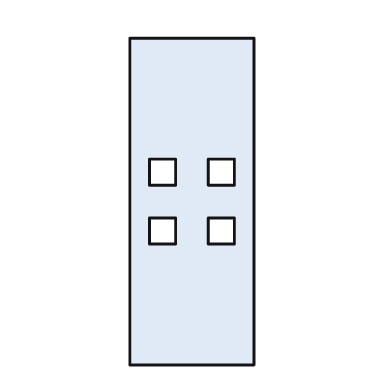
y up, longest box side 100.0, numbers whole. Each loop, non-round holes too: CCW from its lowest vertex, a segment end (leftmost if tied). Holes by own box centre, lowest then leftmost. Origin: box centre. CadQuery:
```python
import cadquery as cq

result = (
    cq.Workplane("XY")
    .moveTo(-19.0, -50.0)
    .lineTo(19.0, -50.0)
    .lineTo(19.0, 50.0)
    .lineTo(-19.0, 50.0)
    .close()
    .moveTo(-13.0, -13.0)
    .lineTo(-5.0, -13.0)
    .lineTo(-5.0, -5.0)
    .lineTo(-13.0, -5.0)
    .close()
    .moveTo(5.0, -13.0)
    .lineTo(13.0, -13.0)
    .lineTo(13.0, -5.0)
    .lineTo(5.0, -5.0)
    .close()
    .moveTo(-13.0, 5.0)
    .lineTo(-5.0, 5.0)
    .lineTo(-5.0, 13.0)
    .lineTo(-13.0, 13.0)
    .close()
    .moveTo(5.0, 5.0)
    .lineTo(13.0, 5.0)
    .lineTo(13.0, 13.0)
    .lineTo(5.0, 13.0)
    .close()
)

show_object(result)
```